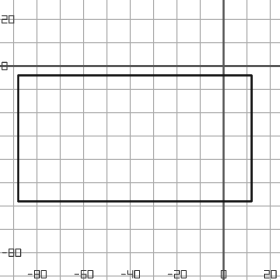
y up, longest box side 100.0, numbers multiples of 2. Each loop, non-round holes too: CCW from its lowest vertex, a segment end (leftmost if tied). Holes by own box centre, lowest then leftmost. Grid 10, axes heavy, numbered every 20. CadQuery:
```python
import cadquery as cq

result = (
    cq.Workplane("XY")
    .moveTo(-88.0, -58.0)
    .lineTo(12.0, -58.0)
    .lineTo(12.0, -4.0)
    .lineTo(-88.0, -4.0)
    .close()
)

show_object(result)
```